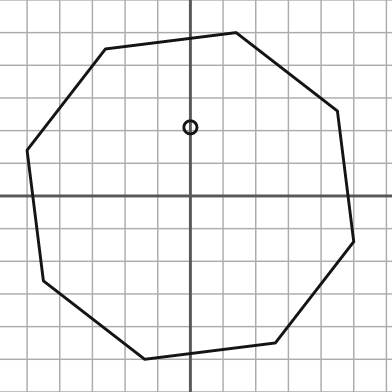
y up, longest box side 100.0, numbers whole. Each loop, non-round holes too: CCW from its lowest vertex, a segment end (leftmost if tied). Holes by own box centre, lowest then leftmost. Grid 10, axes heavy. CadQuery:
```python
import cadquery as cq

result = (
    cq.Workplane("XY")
    .moveTo(-14.0, -50.0)
    .lineTo(26.0, -45.0)
    .lineTo(50.0, -14.0)
    .lineTo(45.0, 26.0)
    .lineTo(14.0, 50.0)
    .lineTo(-26.0, 45.0)
    .lineTo(-50.0, 14.0)
    .lineTo(-45.0, -26.0)
    .close()
    .moveTo(0.0, 21.0)
    .circle(2.0)
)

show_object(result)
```